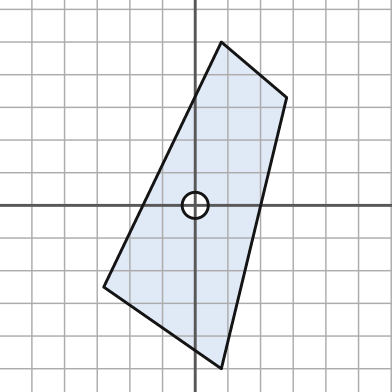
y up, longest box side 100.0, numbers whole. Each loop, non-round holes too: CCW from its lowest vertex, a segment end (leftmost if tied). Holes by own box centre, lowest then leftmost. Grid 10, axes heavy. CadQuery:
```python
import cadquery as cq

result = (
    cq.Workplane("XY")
    .moveTo(8.0, -50.0)
    .lineTo(28.0, 33.0)
    .lineTo(8.0, 50.0)
    .lineTo(-28.0, -25.0)
    .close()
    .moveTo(0.0, 0.0)
    .circle(4.0)
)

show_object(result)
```